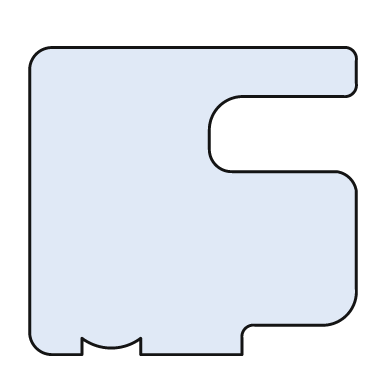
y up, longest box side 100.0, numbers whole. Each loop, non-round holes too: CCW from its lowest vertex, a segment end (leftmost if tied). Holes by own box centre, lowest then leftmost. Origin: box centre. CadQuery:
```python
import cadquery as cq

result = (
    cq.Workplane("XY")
    .moveTo(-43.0, -47.0)
    .lineTo(-34.0, -47.0)
    .lineTo(-34.0, -42.0)
    .threePointArc((-25.0, -45.0), (-16.0, -42.0))
    .lineTo(-16.0, -47.0)
    .lineTo(15.0, -47.0)
    .lineTo(15.0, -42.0)
    .threePointArc((16.0, -39.0), (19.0, -38.0))
    .lineTo(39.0, -38.0)
    .threePointArc((47.0, -35.0), (50.0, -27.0))
    .lineTo(50.0, 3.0)
    .threePointArc((48.0, 7.0), (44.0, 9.0))
    .lineTo(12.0, 9.0)
    .threePointArc((7.0, 11.0), (5.0, 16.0))
    .lineTo(5.0, 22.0)
    .threePointArc((8.0, 29.0), (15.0, 32.0))
    .lineTo(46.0, 32.0)
    .threePointArc((49.0, 33.0), (50.0, 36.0))
    .lineTo(50.0, 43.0)
    .threePointArc((49.0, 46.0), (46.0, 47.0))
    .lineTo(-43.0, 47.0)
    .threePointArc((-48.0, 45.0), (-50.0, 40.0))
    .lineTo(-50.0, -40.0)
    .threePointArc((-48.0, -45.0), (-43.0, -47.0))
    .close()
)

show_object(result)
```